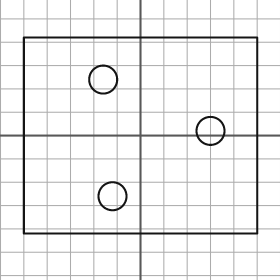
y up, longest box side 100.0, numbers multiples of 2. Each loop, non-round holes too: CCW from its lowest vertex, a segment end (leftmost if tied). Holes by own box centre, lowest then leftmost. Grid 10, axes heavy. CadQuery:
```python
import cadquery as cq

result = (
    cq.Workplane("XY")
    .moveTo(-50.0, -42.0)
    .lineTo(50.0, -42.0)
    .lineTo(50.0, 42.0)
    .lineTo(-50.0, 42.0)
    .close()
    .moveTo(-12.0, -26.0)
    .circle(6.0)
    .moveTo(30.0, 2.0)
    .circle(6.0)
    .moveTo(-16.0, 24.0)
    .circle(6.0)
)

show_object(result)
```